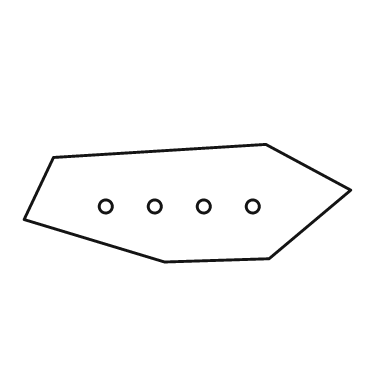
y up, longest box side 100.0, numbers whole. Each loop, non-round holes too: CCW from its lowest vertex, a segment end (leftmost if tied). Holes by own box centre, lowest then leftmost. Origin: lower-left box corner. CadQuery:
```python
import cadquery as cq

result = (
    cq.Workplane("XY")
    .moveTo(43.0, 0.0)
    .lineTo(75.0, 1.0)
    .lineTo(100.0, 22.0)
    .lineTo(74.0, 36.0)
    .lineTo(9.0, 32.0)
    .lineTo(0.0, 13.0)
    .close()
    .moveTo(25.0, 17.0)
    .circle(2.0)
    .moveTo(40.0, 17.0)
    .circle(2.0)
    .moveTo(55.0, 17.0)
    .circle(2.0)
    .moveTo(70.0, 17.0)
    .circle(2.0)
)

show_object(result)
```